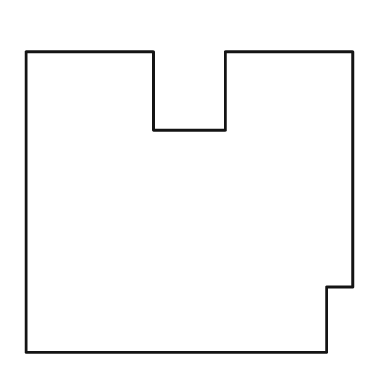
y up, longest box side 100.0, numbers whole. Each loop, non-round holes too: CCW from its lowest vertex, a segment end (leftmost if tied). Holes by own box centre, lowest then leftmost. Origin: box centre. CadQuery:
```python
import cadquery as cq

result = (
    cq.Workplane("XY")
    .moveTo(-50.0, -46.0)
    .lineTo(42.0, -46.0)
    .lineTo(42.0, -26.0)
    .lineTo(50.0, -26.0)
    .lineTo(50.0, 46.0)
    .lineTo(11.0, 46.0)
    .lineTo(11.0, 22.0)
    .lineTo(-11.0, 22.0)
    .lineTo(-11.0, 46.0)
    .lineTo(-50.0, 46.0)
    .close()
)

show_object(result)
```